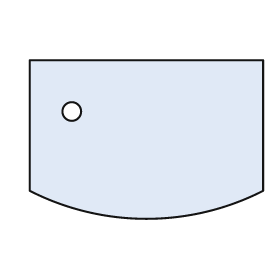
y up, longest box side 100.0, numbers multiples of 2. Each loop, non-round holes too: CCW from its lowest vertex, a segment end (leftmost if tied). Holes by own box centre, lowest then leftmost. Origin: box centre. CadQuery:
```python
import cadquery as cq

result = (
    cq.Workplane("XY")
    .moveTo(-50.0, -22.0)
    .threePointArc((0.0, -34.0), (50.0, -22.0))
    .lineTo(50.0, 34.0)
    .lineTo(-50.0, 34.0)
    .close()
    .moveTo(-32.0, 12.0)
    .circle(4.0)
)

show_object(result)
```